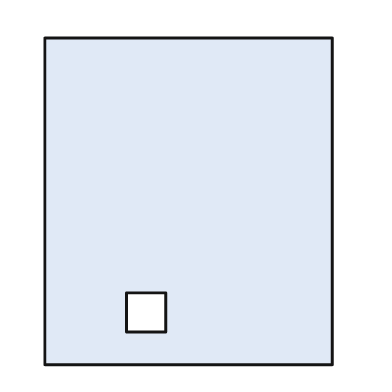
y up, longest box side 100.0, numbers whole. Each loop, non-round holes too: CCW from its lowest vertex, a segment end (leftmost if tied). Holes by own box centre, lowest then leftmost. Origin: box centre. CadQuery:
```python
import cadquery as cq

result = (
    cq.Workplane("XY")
    .moveTo(-44.0, -50.0)
    .lineTo(44.0, -50.0)
    .lineTo(44.0, 50.0)
    .lineTo(-44.0, 50.0)
    .close()
    .moveTo(-19.0, -40.0)
    .lineTo(-7.0, -40.0)
    .lineTo(-7.0, -28.0)
    .lineTo(-19.0, -28.0)
    .close()
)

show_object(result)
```